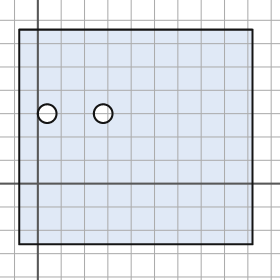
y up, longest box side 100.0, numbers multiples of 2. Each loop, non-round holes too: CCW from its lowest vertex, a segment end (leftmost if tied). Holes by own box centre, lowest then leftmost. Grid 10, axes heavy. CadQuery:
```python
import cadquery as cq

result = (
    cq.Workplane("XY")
    .moveTo(-8.0, -26.0)
    .lineTo(92.0, -26.0)
    .lineTo(92.0, 66.0)
    .lineTo(-8.0, 66.0)
    .close()
    .moveTo(4.0, 30.0)
    .circle(4.0)
    .moveTo(28.0, 30.0)
    .circle(4.0)
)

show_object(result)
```